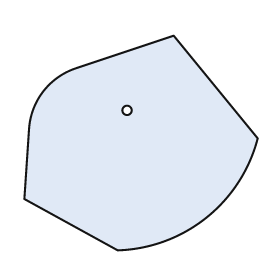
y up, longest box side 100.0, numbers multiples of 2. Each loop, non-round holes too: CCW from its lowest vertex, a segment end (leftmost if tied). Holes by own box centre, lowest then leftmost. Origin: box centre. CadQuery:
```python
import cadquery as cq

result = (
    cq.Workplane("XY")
    .moveTo(-10.0, -46.0)
    .threePointArc((28.0, -32.0), (50.0, 2.0))
    .lineTo(14.0, 46.0)
    .lineTo(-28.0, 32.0)
    .threePointArc((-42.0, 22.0), (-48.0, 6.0))
    .lineTo(-50.0, -24.0)
    .close()
    .moveTo(-6.0, 14.0)
    .circle(2.0)
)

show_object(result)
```